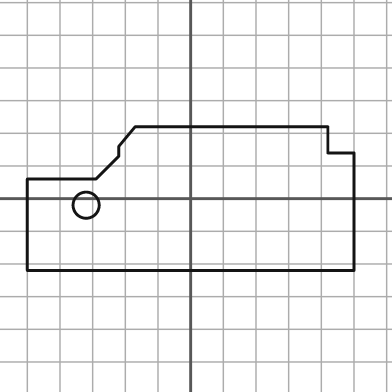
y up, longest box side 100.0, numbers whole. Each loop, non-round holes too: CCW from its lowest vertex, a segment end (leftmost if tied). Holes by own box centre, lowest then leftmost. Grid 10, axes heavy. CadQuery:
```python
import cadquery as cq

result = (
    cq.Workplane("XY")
    .moveTo(-50.0, -22.0)
    .lineTo(50.0, -22.0)
    .lineTo(50.0, 14.0)
    .lineTo(42.0, 14.0)
    .lineTo(42.0, 22.0)
    .lineTo(-17.0, 22.0)
    .lineTo(-22.0, 16.0)
    .lineTo(-22.0, 13.0)
    .lineTo(-29.0, 6.0)
    .lineTo(-50.0, 6.0)
    .close()
    .moveTo(-32.0, -2.0)
    .circle(4.0)
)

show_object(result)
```